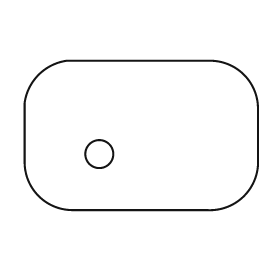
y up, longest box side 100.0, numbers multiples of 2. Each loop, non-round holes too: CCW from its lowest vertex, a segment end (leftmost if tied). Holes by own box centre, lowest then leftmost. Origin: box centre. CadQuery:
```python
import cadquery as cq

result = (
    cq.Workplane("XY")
    .moveTo(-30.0, -32.0)
    .lineTo(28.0, -32.0)
    .threePointArc((44.0, -26.0), (50.0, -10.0))
    .lineTo(50.0, 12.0)
    .threePointArc((44.0, 26.0), (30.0, 32.0))
    .lineTo(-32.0, 32.0)
    .threePointArc((-44.0, 26.0), (-50.0, 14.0))
    .lineTo(-50.0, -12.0)
    .threePointArc((-44.0, -26.0), (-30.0, -32.0))
    .close()
    .moveTo(-18.0, -8.0)
    .circle(6.0)
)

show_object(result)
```